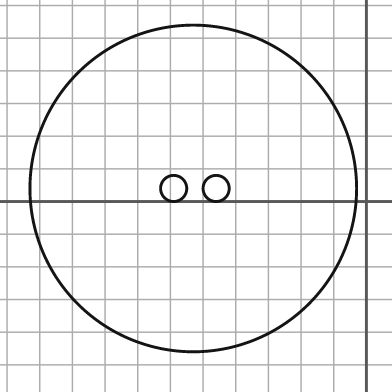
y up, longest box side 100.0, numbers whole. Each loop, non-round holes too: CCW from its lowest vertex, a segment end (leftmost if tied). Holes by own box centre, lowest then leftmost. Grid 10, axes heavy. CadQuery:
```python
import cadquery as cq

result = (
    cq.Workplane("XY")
    .moveTo(-53.0, 4.0)
    .circle(50.0)
    .moveTo(-59.0, 4.0)
    .circle(4.0)
    .moveTo(-46.0, 4.0)
    .circle(4.0)
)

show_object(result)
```